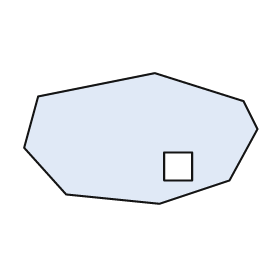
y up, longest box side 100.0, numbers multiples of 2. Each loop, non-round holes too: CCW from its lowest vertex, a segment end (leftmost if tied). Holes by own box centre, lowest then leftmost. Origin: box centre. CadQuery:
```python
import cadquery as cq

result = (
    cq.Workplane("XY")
    .moveTo(8.0, -28.0)
    .lineTo(38.0, -18.0)
    .lineTo(50.0, 4.0)
    .lineTo(44.0, 16.0)
    .lineTo(6.0, 28.0)
    .lineTo(-44.0, 18.0)
    .lineTo(-50.0, -4.0)
    .lineTo(-32.0, -24.0)
    .close()
    .moveTo(10.0, -18.0)
    .lineTo(22.0, -18.0)
    .lineTo(22.0, -6.0)
    .lineTo(10.0, -6.0)
    .close()
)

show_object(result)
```